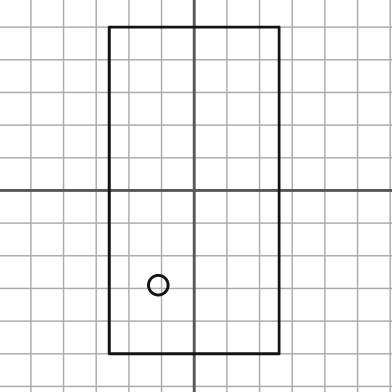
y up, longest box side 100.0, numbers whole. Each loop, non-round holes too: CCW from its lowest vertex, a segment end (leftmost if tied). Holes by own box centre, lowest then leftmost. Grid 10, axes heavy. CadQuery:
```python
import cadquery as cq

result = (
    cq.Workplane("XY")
    .moveTo(-26.0, -50.0)
    .lineTo(26.0, -50.0)
    .lineTo(26.0, 50.0)
    .lineTo(-26.0, 50.0)
    .close()
    .moveTo(-11.0, -29.0)
    .circle(3.0)
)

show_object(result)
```